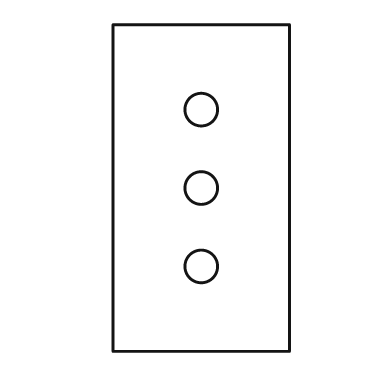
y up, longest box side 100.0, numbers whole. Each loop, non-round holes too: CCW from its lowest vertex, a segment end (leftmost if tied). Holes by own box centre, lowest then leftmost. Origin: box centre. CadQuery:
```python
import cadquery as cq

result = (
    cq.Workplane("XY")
    .moveTo(-27.0, -50.0)
    .lineTo(27.0, -50.0)
    .lineTo(27.0, 50.0)
    .lineTo(-27.0, 50.0)
    .close()
    .moveTo(0.0, -24.0)
    .circle(5.0)
    .moveTo(0.0, 0.0)
    .circle(5.0)
    .moveTo(0.0, 24.0)
    .circle(5.0)
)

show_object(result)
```